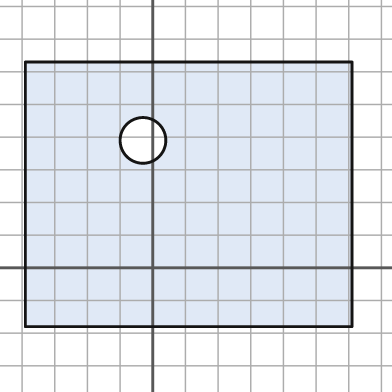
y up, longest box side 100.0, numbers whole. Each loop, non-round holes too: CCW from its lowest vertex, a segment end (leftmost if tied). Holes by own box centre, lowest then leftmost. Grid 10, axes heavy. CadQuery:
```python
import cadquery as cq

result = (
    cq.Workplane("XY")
    .moveTo(-39.0, -18.0)
    .lineTo(61.0, -18.0)
    .lineTo(61.0, 63.0)
    .lineTo(-39.0, 63.0)
    .close()
    .moveTo(-3.0, 39.0)
    .circle(7.0)
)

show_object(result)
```